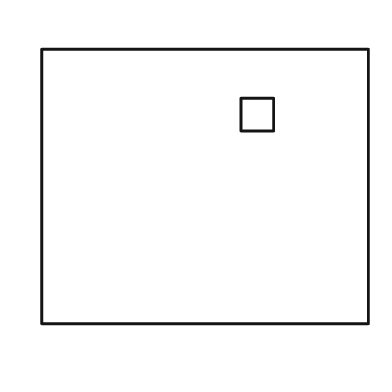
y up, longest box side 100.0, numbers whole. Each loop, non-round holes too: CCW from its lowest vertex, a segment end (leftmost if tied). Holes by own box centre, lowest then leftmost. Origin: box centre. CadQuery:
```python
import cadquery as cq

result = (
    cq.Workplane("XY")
    .moveTo(-50.0, -42.0)
    .lineTo(50.0, -42.0)
    .lineTo(50.0, 42.0)
    .lineTo(-50.0, 42.0)
    .close()
    .moveTo(11.0, 17.0)
    .lineTo(21.0, 17.0)
    .lineTo(21.0, 27.0)
    .lineTo(11.0, 27.0)
    .close()
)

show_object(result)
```